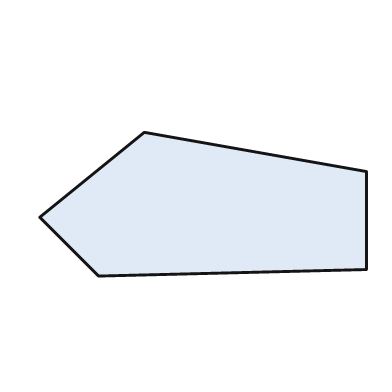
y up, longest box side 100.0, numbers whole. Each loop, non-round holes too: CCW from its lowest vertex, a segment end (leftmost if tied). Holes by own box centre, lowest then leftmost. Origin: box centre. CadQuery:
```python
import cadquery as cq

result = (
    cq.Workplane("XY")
    .moveTo(-32.0, -22.0)
    .lineTo(50.0, -20.0)
    .lineTo(50.0, 10.0)
    .lineTo(-18.0, 22.0)
    .lineTo(-50.0, -4.0)
    .close()
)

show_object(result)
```